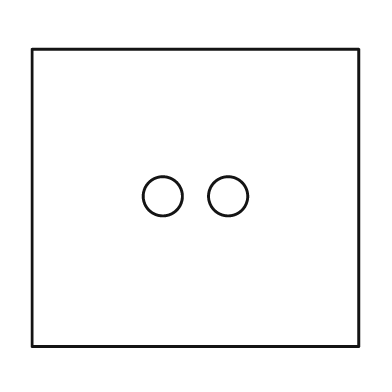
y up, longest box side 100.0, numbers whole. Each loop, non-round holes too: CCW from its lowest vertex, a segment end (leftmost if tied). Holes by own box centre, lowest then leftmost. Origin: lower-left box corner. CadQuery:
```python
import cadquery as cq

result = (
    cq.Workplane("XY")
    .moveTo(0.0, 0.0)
    .lineTo(100.0, 0.0)
    .lineTo(100.0, 91.0)
    .lineTo(0.0, 91.0)
    .close()
    .moveTo(40.0, 46.0)
    .circle(6.0)
    .moveTo(60.0, 46.0)
    .circle(6.0)
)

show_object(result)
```